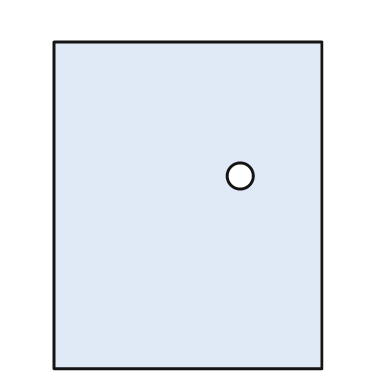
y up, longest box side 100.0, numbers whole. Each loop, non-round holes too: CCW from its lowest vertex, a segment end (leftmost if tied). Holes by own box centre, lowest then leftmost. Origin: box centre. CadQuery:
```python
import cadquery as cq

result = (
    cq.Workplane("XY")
    .moveTo(-41.0, -50.0)
    .lineTo(41.0, -50.0)
    .lineTo(41.0, 50.0)
    .lineTo(-41.0, 50.0)
    .close()
    .moveTo(16.0, 9.0)
    .circle(4.0)
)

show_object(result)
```